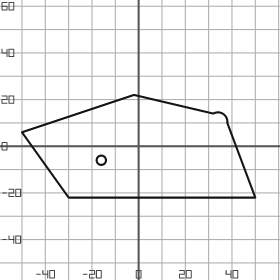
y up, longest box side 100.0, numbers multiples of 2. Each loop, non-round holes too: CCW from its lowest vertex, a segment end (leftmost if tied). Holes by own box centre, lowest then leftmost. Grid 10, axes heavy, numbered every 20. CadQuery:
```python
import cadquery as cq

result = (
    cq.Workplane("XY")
    .moveTo(-30.0, -22.0)
    .lineTo(50.0, -22.0)
    .lineTo(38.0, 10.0)
    .threePointArc((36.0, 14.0), (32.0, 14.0))
    .lineTo(-2.0, 22.0)
    .lineTo(-50.0, 6.0)
    .close()
    .moveTo(-16.0, -6.0)
    .circle(2.0)
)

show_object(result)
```